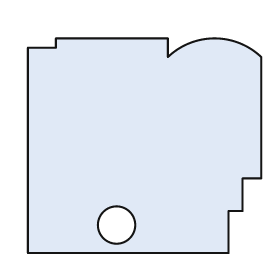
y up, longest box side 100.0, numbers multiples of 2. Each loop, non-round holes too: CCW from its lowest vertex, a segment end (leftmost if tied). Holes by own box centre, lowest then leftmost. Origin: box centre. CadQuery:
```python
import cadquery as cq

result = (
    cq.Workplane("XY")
    .moveTo(-50.0, -46.0)
    .lineTo(36.0, -46.0)
    .lineTo(36.0, -28.0)
    .lineTo(42.0, -28.0)
    .lineTo(42.0, -14.0)
    .lineTo(50.0, -14.0)
    .lineTo(50.0, 38.0)
    .threePointArc((30.0, 46.0), (10.0, 38.0))
    .lineTo(10.0, 46.0)
    .lineTo(-38.0, 46.0)
    .lineTo(-38.0, 42.0)
    .lineTo(-50.0, 42.0)
    .close()
    .moveTo(-12.0, -34.0)
    .circle(8.0)
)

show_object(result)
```